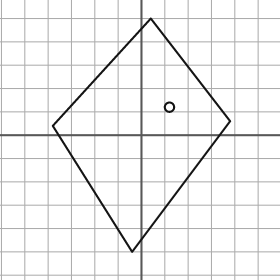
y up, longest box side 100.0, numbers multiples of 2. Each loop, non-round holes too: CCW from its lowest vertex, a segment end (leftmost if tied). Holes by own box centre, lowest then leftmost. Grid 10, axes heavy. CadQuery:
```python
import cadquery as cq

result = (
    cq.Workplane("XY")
    .moveTo(-4.0, -50.0)
    .lineTo(38.0, 6.0)
    .lineTo(4.0, 50.0)
    .lineTo(-38.0, 4.0)
    .close()
    .moveTo(12.0, 12.0)
    .circle(2.0)
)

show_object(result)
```